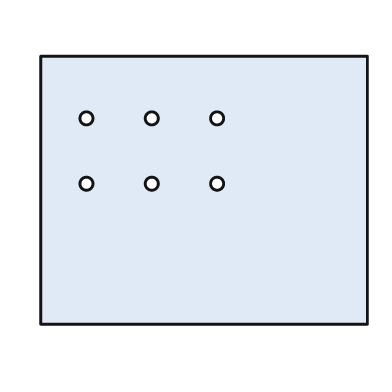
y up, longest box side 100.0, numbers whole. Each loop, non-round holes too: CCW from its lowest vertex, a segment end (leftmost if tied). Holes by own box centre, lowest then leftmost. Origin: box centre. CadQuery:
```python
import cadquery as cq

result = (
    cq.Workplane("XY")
    .moveTo(-50.0, -41.0)
    .lineTo(50.0, -41.0)
    .lineTo(50.0, 41.0)
    .lineTo(-50.0, 41.0)
    .close()
    .moveTo(-36.0, 2.0)
    .circle(2.0)
    .moveTo(-16.0, 2.0)
    .circle(2.0)
    .moveTo(4.0, 2.0)
    .circle(2.0)
    .moveTo(-36.0, 22.0)
    .circle(2.0)
    .moveTo(-16.0, 22.0)
    .circle(2.0)
    .moveTo(4.0, 22.0)
    .circle(2.0)
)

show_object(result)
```